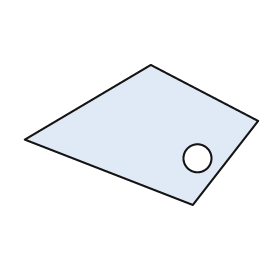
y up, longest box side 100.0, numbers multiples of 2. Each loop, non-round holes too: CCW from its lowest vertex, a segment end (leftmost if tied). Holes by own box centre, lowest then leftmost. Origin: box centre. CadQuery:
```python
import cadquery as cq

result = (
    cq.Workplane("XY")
    .moveTo(22.0, -30.0)
    .lineTo(50.0, 6.0)
    .lineTo(4.0, 30.0)
    .lineTo(-50.0, -2.0)
    .close()
    .moveTo(24.0, -10.0)
    .circle(6.0)
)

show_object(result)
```